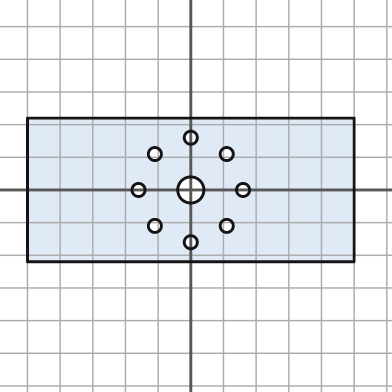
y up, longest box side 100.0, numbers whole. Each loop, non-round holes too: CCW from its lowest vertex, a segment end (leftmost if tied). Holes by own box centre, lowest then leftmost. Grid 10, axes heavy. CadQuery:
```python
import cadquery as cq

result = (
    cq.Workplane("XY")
    .moveTo(-50.0, -22.0)
    .lineTo(50.0, -22.0)
    .lineTo(50.0, 22.0)
    .lineTo(-50.0, 22.0)
    .close()
    .moveTo(0.0, -16.0)
    .circle(2.0)
    .moveTo(-11.0, -11.0)
    .circle(2.0)
    .moveTo(11.0, -11.0)
    .circle(2.0)
    .moveTo(-16.0, 0.0)
    .circle(2.0)
    .moveTo(0.0, 0.0)
    .circle(4.0)
    .moveTo(16.0, 0.0)
    .circle(2.0)
    .moveTo(-11.0, 11.0)
    .circle(2.0)
    .moveTo(11.0, 11.0)
    .circle(2.0)
    .moveTo(0.0, 16.0)
    .circle(2.0)
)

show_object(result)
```